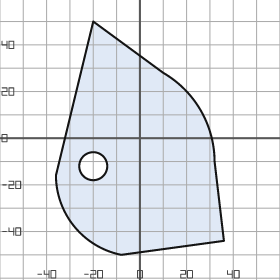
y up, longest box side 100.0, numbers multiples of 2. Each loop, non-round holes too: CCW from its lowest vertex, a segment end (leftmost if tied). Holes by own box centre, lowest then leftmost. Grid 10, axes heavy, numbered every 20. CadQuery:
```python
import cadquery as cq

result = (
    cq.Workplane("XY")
    .moveTo(-8.0, -50.0)
    .lineTo(36.0, -44.0)
    .lineTo(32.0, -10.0)
    .threePointArc((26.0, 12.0), (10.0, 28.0))
    .lineTo(-20.0, 50.0)
    .lineTo(-36.0, -16.0)
    .threePointArc((-28.0, -38.0), (-8.0, -50.0))
    .close()
    .moveTo(-20.0, -12.0)
    .circle(6.0)
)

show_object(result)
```